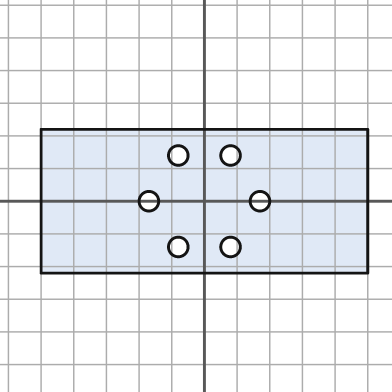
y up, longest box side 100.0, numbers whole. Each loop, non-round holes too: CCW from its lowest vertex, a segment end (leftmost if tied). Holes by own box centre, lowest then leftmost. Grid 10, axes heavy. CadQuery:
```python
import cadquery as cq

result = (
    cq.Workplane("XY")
    .moveTo(-50.0, -22.0)
    .lineTo(50.0, -22.0)
    .lineTo(50.0, 22.0)
    .lineTo(-50.0, 22.0)
    .close()
    .moveTo(-8.0, -14.0)
    .circle(3.0)
    .moveTo(8.0, -14.0)
    .circle(3.0)
    .moveTo(-17.0, 0.0)
    .circle(3.0)
    .moveTo(17.0, 0.0)
    .circle(3.0)
    .moveTo(-8.0, 14.0)
    .circle(3.0)
    .moveTo(8.0, 14.0)
    .circle(3.0)
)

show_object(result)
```